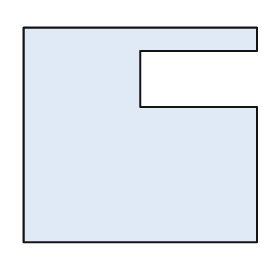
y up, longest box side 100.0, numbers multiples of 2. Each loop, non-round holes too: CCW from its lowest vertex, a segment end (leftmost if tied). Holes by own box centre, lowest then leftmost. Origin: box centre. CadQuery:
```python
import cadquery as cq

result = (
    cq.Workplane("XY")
    .moveTo(-50.0, -46.0)
    .lineTo(50.0, -46.0)
    .lineTo(50.0, 12.0)
    .lineTo(0.0, 12.0)
    .lineTo(0.0, 36.0)
    .lineTo(50.0, 36.0)
    .lineTo(50.0, 46.0)
    .lineTo(-50.0, 46.0)
    .close()
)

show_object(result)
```